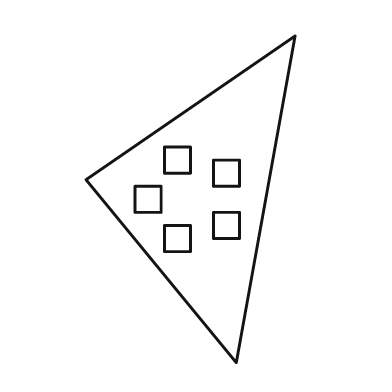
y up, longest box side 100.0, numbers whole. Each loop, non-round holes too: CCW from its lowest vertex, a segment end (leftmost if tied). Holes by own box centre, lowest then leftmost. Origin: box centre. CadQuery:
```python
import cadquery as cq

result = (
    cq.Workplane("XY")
    .moveTo(14.0, -50.0)
    .lineTo(32.0, 50.0)
    .lineTo(-32.0, 6.0)
    .close()
    .moveTo(-8.0, -16.0)
    .lineTo(0.0, -16.0)
    .lineTo(0.0, -8.0)
    .lineTo(-8.0, -8.0)
    .close()
    .moveTo(7.0, -12.0)
    .lineTo(15.0, -12.0)
    .lineTo(15.0, -4.0)
    .lineTo(7.0, -4.0)
    .close()
    .moveTo(-17.0, -4.0)
    .lineTo(-9.0, -4.0)
    .lineTo(-9.0, 4.0)
    .lineTo(-17.0, 4.0)
    .close()
    .moveTo(7.0, 4.0)
    .lineTo(15.0, 4.0)
    .lineTo(15.0, 12.0)
    .lineTo(7.0, 12.0)
    .close()
    .moveTo(-8.0, 8.0)
    .lineTo(0.0, 8.0)
    .lineTo(0.0, 16.0)
    .lineTo(-8.0, 16.0)
    .close()
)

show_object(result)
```